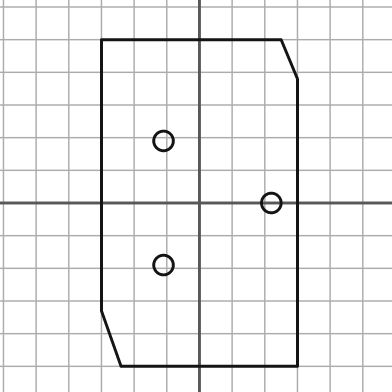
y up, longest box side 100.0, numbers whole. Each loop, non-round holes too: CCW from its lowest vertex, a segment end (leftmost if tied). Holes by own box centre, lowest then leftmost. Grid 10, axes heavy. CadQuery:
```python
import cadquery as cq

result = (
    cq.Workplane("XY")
    .moveTo(-24.0, -50.0)
    .lineTo(30.0, -50.0)
    .lineTo(30.0, 38.0)
    .lineTo(25.0, 50.0)
    .lineTo(-30.0, 50.0)
    .lineTo(-30.0, -33.0)
    .close()
    .moveTo(-11.0, -19.0)
    .circle(3.0)
    .moveTo(22.0, 0.0)
    .circle(3.0)
    .moveTo(-11.0, 19.0)
    .circle(3.0)
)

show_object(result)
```